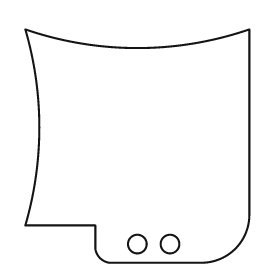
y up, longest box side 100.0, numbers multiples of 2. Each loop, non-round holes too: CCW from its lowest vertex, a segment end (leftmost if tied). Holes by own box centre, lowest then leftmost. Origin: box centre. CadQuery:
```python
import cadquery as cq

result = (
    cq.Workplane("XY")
    .moveTo(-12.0, -50.0)
    .lineTo(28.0, -50.0)
    .threePointArc((42.0, -44.0), (48.0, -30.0))
    .lineTo(48.0, 50.0)
    .threePointArc((0.0, 42.0), (-48.0, 50.0))
    .threePointArc((-42.0, 8.0), (-48.0, -34.0))
    .lineTo(-18.0, -34.0)
    .lineTo(-18.0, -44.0)
    .threePointArc((-16.0, -48.0), (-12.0, -50.0))
    .close()
    .moveTo(0.0, -42.0)
    .circle(4.0)
    .moveTo(14.0, -42.0)
    .circle(4.0)
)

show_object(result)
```